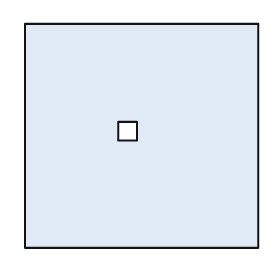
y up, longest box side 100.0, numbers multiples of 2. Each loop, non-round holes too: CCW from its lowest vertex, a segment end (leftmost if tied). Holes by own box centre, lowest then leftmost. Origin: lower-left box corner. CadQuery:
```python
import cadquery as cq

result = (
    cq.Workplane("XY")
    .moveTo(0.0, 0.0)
    .lineTo(100.0, 0.0)
    .lineTo(100.0, 96.0)
    .lineTo(0.0, 96.0)
    .close()
    .moveTo(40.0, 46.0)
    .lineTo(48.0, 46.0)
    .lineTo(48.0, 54.0)
    .lineTo(40.0, 54.0)
    .close()
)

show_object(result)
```